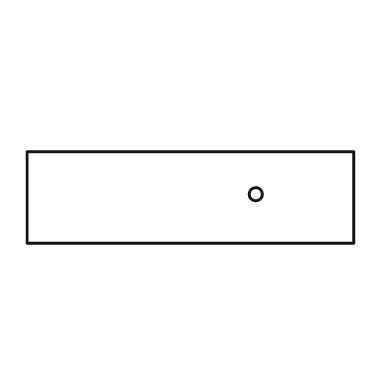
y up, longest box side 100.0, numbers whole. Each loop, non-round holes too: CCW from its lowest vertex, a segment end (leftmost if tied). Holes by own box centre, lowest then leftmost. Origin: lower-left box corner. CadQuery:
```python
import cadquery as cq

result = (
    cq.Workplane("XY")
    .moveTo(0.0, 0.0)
    .lineTo(100.0, 0.0)
    .lineTo(100.0, 28.0)
    .lineTo(0.0, 28.0)
    .close()
    .moveTo(70.0, 15.0)
    .circle(2.0)
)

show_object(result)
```